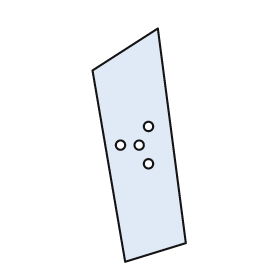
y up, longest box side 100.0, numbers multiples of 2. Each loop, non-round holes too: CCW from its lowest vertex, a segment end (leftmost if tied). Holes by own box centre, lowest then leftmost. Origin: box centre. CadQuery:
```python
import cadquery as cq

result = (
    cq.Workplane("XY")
    .moveTo(-6.0, -50.0)
    .lineTo(20.0, -42.0)
    .lineTo(8.0, 50.0)
    .lineTo(-20.0, 32.0)
    .close()
    .moveTo(4.0, -8.0)
    .circle(2.0)
    .moveTo(-8.0, 0.0)
    .circle(2.0)
    .moveTo(0.0, 0.0)
    .circle(2.0)
    .moveTo(4.0, 8.0)
    .circle(2.0)
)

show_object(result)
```